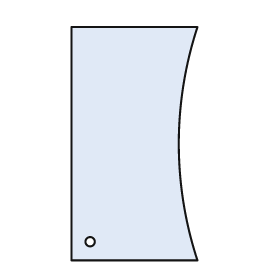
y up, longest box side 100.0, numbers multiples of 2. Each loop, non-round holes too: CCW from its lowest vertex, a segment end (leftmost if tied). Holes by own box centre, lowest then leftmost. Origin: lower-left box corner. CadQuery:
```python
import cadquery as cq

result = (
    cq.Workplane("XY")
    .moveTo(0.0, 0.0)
    .lineTo(54.0, 0.0)
    .threePointArc((46.0, 50.0), (54.0, 100.0))
    .lineTo(0.0, 100.0)
    .close()
    .moveTo(8.0, 8.0)
    .circle(2.0)
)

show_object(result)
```